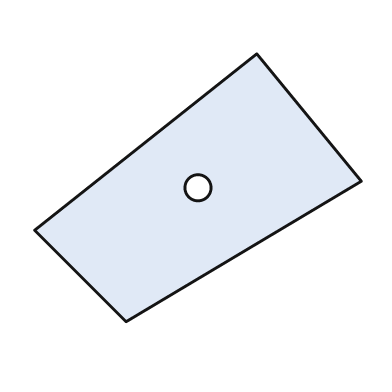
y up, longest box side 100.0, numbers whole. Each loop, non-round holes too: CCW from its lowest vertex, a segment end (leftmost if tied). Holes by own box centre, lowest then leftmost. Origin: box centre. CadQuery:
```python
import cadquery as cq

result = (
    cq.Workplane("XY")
    .moveTo(-22.0, -41.0)
    .lineTo(50.0, 2.0)
    .lineTo(18.0, 41.0)
    .lineTo(-50.0, -13.0)
    .close()
    .moveTo(0.0, 0.0)
    .circle(4.0)
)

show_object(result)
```